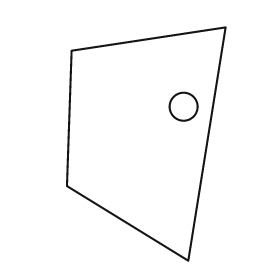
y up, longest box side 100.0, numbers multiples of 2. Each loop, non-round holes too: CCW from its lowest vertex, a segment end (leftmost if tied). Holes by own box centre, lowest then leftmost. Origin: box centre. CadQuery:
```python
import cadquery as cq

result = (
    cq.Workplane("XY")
    .moveTo(18.0, -50.0)
    .lineTo(34.0, 50.0)
    .lineTo(-32.0, 40.0)
    .lineTo(-34.0, -18.0)
    .close()
    .moveTo(16.0, 16.0)
    .circle(6.0)
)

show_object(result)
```